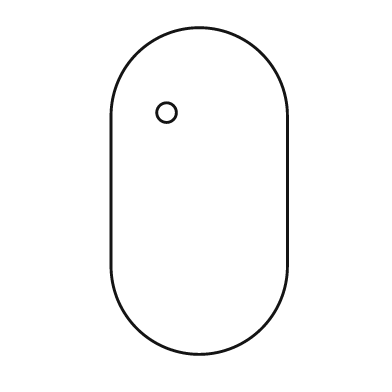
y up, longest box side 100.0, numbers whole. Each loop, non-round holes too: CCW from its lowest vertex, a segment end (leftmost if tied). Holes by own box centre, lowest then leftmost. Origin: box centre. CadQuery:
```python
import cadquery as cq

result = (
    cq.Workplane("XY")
    .moveTo(-27.0, -23.0)
    .threePointArc((0.0, -50.0), (27.0, -23.0))
    .lineTo(27.0, 23.0)
    .threePointArc((0.0, 50.0), (-27.0, 23.0))
    .close()
    .moveTo(-10.0, 24.0)
    .circle(3.0)
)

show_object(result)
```